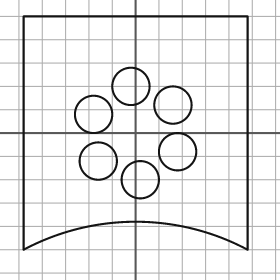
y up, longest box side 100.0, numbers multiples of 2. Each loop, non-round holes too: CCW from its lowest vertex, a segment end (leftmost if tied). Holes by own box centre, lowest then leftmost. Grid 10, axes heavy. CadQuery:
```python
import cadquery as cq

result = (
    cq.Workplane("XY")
    .moveTo(-48.0, -50.0)
    .threePointArc((0.0, -38.0), (48.0, -50.0))
    .lineTo(48.0, 50.0)
    .lineTo(-48.0, 50.0)
    .close()
    .moveTo(2.0, -20.0)
    .circle(8.0)
    .moveTo(-16.0, -12.0)
    .circle(8.0)
    .moveTo(18.0, -8.0)
    .circle(8.0)
    .moveTo(-18.0, 8.0)
    .circle(8.0)
    .moveTo(16.0, 12.0)
    .circle(8.0)
    .moveTo(-2.0, 20.0)
    .circle(8.0)
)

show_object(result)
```